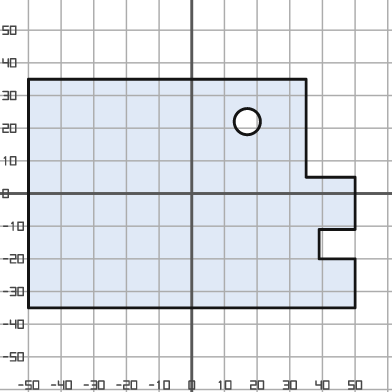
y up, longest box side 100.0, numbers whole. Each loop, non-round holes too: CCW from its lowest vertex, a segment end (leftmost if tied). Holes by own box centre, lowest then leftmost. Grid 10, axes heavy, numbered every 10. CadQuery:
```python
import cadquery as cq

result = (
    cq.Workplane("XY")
    .moveTo(-50.0, -35.0)
    .lineTo(50.0, -35.0)
    .lineTo(50.0, -20.0)
    .lineTo(39.0, -20.0)
    .lineTo(39.0, -11.0)
    .lineTo(50.0, -11.0)
    .lineTo(50.0, 5.0)
    .lineTo(35.0, 5.0)
    .lineTo(35.0, 35.0)
    .lineTo(-50.0, 35.0)
    .close()
    .moveTo(17.0, 22.0)
    .circle(4.0)
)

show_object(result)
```